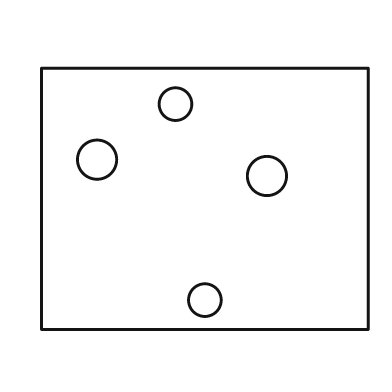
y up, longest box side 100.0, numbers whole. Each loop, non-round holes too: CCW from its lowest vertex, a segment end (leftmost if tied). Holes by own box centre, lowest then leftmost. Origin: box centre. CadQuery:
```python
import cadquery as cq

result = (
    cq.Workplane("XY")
    .moveTo(-50.0, -40.0)
    .lineTo(50.0, -40.0)
    .lineTo(50.0, 40.0)
    .lineTo(-50.0, 40.0)
    .close()
    .moveTo(0.0, -31.0)
    .circle(5.0)
    .moveTo(19.0, 7.0)
    .circle(6.0)
    .moveTo(-33.0, 12.0)
    .circle(6.0)
    .moveTo(-9.0, 29.0)
    .circle(5.0)
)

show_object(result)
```